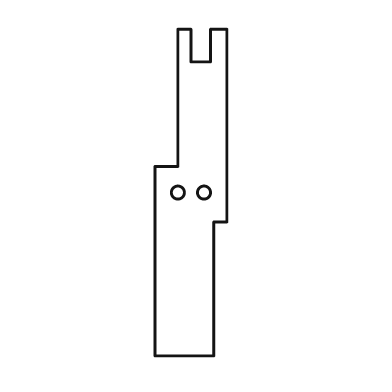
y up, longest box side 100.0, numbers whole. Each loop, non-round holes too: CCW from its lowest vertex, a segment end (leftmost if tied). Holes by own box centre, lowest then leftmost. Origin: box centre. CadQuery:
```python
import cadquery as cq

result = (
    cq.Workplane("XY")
    .moveTo(-11.0, -50.0)
    .lineTo(7.0, -50.0)
    .lineTo(7.0, -9.0)
    .lineTo(11.0, -9.0)
    .lineTo(11.0, 50.0)
    .lineTo(6.0, 50.0)
    .lineTo(6.0, 40.0)
    .lineTo(0.0, 40.0)
    .lineTo(0.0, 50.0)
    .lineTo(-4.0, 50.0)
    .lineTo(-4.0, 8.0)
    .lineTo(-11.0, 8.0)
    .close()
    .moveTo(-4.0, 0.0)
    .circle(2.0)
    .moveTo(4.0, 0.0)
    .circle(2.0)
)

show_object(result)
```